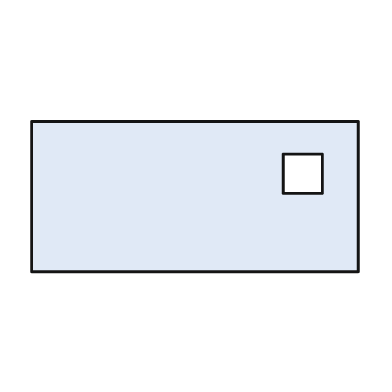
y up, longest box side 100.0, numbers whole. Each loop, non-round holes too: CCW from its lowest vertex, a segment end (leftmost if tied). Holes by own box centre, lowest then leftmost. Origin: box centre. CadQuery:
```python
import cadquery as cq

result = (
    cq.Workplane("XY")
    .moveTo(-50.0, -23.0)
    .lineTo(50.0, -23.0)
    .lineTo(50.0, 23.0)
    .lineTo(-50.0, 23.0)
    .close()
    .moveTo(27.0, 1.0)
    .lineTo(39.0, 1.0)
    .lineTo(39.0, 13.0)
    .lineTo(27.0, 13.0)
    .close()
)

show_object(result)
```